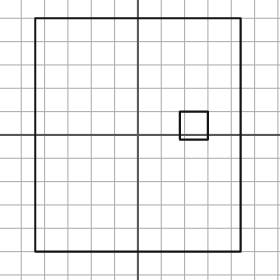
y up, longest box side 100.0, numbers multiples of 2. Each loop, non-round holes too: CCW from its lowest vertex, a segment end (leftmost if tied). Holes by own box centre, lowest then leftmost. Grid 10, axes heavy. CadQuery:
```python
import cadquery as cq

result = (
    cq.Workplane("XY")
    .moveTo(-44.0, -50.0)
    .lineTo(44.0, -50.0)
    .lineTo(44.0, 50.0)
    .lineTo(-44.0, 50.0)
    .close()
    .moveTo(18.0, -2.0)
    .lineTo(30.0, -2.0)
    .lineTo(30.0, 10.0)
    .lineTo(18.0, 10.0)
    .close()
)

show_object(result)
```